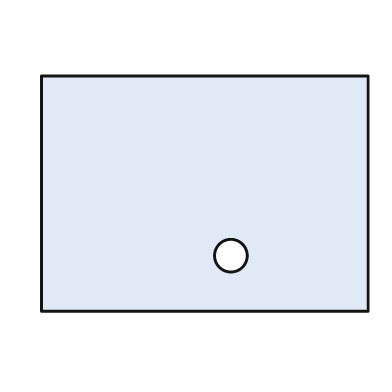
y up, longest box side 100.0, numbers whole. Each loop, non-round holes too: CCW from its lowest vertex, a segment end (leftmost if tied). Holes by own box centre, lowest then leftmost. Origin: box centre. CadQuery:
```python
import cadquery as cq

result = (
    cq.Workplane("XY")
    .moveTo(-50.0, -36.0)
    .lineTo(50.0, -36.0)
    .lineTo(50.0, 36.0)
    .lineTo(-50.0, 36.0)
    .close()
    .moveTo(8.0, -19.0)
    .circle(5.0)
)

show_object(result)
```